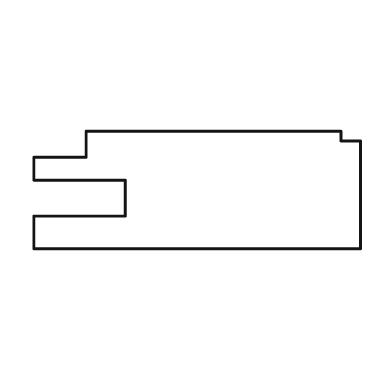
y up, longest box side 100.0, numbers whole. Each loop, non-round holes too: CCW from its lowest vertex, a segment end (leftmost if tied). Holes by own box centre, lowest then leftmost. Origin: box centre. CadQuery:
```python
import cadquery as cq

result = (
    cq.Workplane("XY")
    .moveTo(-50.0, -18.0)
    .lineTo(50.0, -18.0)
    .lineTo(50.0, 15.0)
    .lineTo(44.0, 15.0)
    .lineTo(44.0, 18.0)
    .lineTo(-34.0, 18.0)
    .lineTo(-34.0, 10.0)
    .lineTo(-50.0, 10.0)
    .lineTo(-50.0, 3.0)
    .lineTo(-22.0, 3.0)
    .lineTo(-22.0, -8.0)
    .lineTo(-50.0, -8.0)
    .close()
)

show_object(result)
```